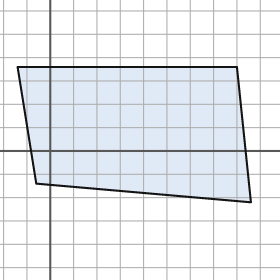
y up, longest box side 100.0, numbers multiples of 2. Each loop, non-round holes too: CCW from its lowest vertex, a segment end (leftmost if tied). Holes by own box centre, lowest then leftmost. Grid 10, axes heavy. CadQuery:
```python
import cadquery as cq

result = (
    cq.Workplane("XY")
    .moveTo(86.0, -22.0)
    .lineTo(80.0, 36.0)
    .lineTo(-14.0, 36.0)
    .lineTo(-6.0, -14.0)
    .close()
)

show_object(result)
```